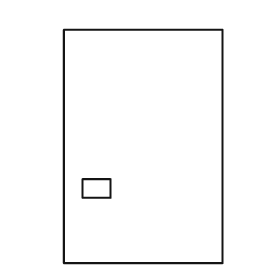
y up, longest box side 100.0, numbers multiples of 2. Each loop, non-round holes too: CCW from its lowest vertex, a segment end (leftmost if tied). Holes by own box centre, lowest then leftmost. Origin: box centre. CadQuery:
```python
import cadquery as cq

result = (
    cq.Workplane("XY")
    .moveTo(-34.0, -50.0)
    .lineTo(34.0, -50.0)
    .lineTo(34.0, 50.0)
    .lineTo(-34.0, 50.0)
    .close()
    .moveTo(-26.0, -22.0)
    .lineTo(-14.0, -22.0)
    .lineTo(-14.0, -14.0)
    .lineTo(-26.0, -14.0)
    .close()
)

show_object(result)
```